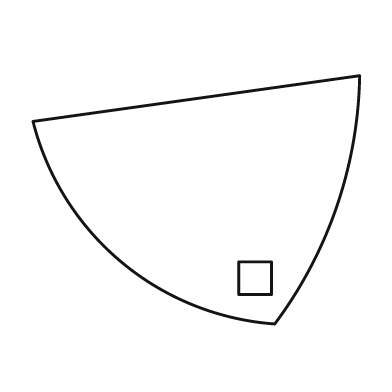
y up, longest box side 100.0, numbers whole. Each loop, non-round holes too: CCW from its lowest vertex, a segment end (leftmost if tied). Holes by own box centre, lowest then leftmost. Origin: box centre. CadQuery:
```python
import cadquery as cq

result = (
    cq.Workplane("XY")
    .moveTo(24.0, -38.0)
    .threePointArc((43.0, -2.0), (50.0, 38.0))
    .lineTo(-50.0, 24.0)
    .threePointArc((-23.0, -19.0), (24.0, -38.0))
    .close()
    .moveTo(13.0, -29.0)
    .lineTo(23.0, -29.0)
    .lineTo(23.0, -19.0)
    .lineTo(13.0, -19.0)
    .close()
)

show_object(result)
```